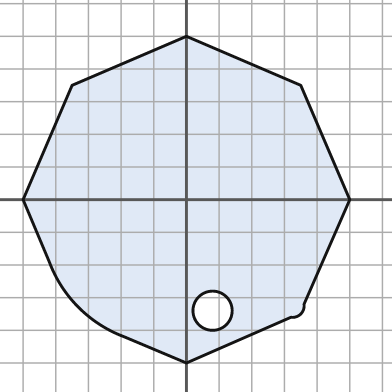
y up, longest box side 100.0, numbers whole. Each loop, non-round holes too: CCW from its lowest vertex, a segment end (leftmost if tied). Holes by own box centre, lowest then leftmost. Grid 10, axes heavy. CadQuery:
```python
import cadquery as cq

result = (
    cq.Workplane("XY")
    .moveTo(0.0, -50.0)
    .lineTo(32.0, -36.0)
    .threePointArc((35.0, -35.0), (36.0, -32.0))
    .lineTo(50.0, 0.0)
    .lineTo(35.0, 35.0)
    .lineTo(0.0, 50.0)
    .lineTo(-35.0, 35.0)
    .lineTo(-50.0, 0.0)
    .lineTo(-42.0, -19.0)
    .threePointArc((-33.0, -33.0), (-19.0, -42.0))
    .close()
    .moveTo(8.0, -34.0)
    .circle(6.0)
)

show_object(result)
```